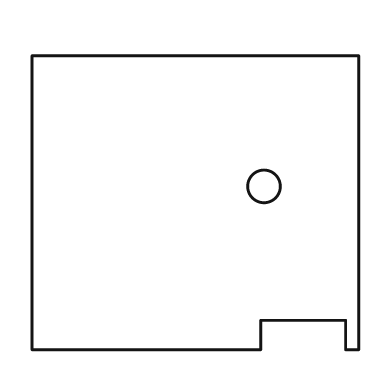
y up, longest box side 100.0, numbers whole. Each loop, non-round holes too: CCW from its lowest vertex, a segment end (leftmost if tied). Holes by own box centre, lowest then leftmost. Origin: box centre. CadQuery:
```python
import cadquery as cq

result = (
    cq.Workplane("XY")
    .moveTo(-50.0, -45.0)
    .lineTo(20.0, -45.0)
    .lineTo(20.0, -36.0)
    .lineTo(46.0, -36.0)
    .lineTo(46.0, -45.0)
    .lineTo(50.0, -45.0)
    .lineTo(50.0, 45.0)
    .lineTo(-50.0, 45.0)
    .close()
    .moveTo(21.0, 5.0)
    .circle(5.0)
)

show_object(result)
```